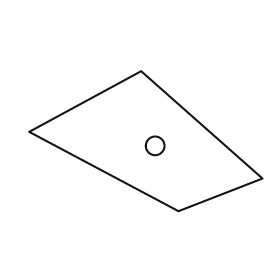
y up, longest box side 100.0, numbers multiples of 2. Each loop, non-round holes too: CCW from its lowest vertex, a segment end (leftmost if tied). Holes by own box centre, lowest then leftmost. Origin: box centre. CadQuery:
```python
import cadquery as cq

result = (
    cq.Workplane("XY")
    .moveTo(14.0, -30.0)
    .lineTo(50.0, -16.0)
    .lineTo(-2.0, 30.0)
    .lineTo(-50.0, 4.0)
    .close()
    .moveTo(4.0, -2.0)
    .circle(4.0)
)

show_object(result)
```